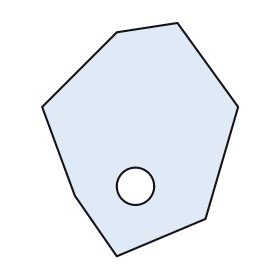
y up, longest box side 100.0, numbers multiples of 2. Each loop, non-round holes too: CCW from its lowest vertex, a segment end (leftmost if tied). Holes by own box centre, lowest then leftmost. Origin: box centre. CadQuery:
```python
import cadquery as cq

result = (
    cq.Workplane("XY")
    .moveTo(-10.0, -50.0)
    .lineTo(28.0, -34.0)
    .lineTo(42.0, 14.0)
    .lineTo(16.0, 50.0)
    .lineTo(-10.0, 46.0)
    .lineTo(-42.0, 14.0)
    .lineTo(-28.0, -24.0)
    .close()
    .moveTo(-2.0, -20.0)
    .circle(8.0)
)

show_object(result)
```